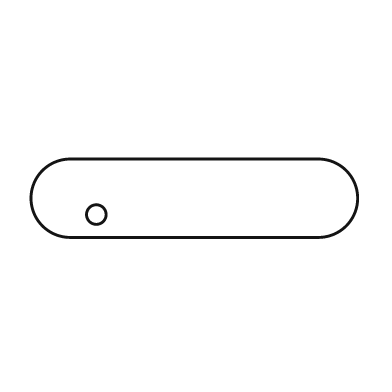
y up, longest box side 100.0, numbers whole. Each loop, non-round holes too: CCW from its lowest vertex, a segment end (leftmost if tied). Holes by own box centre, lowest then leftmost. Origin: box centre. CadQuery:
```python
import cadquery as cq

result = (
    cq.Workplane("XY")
    .moveTo(-38.0, -12.0)
    .lineTo(38.0, -12.0)
    .threePointArc((50.0, 0.0), (38.0, 12.0))
    .lineTo(-38.0, 12.0)
    .threePointArc((-50.0, 0.0), (-38.0, -12.0))
    .close()
    .moveTo(-30.0, -5.0)
    .circle(3.0)
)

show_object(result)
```